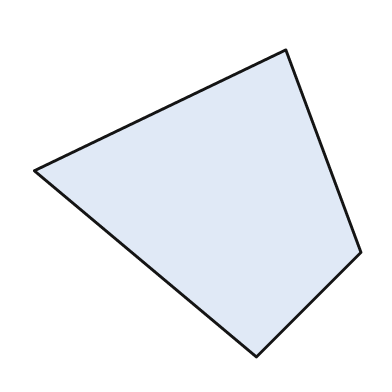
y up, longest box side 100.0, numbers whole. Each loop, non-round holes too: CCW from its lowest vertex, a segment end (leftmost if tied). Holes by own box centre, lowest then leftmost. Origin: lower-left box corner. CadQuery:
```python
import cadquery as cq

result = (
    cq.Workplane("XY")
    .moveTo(68.0, 0.0)
    .lineTo(100.0, 32.0)
    .lineTo(77.0, 94.0)
    .lineTo(0.0, 57.0)
    .close()
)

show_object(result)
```